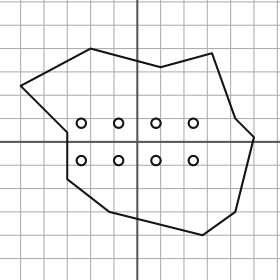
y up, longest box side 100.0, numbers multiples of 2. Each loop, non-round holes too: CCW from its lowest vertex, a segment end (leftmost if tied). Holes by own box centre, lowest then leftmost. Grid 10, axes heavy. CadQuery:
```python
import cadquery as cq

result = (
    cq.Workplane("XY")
    .moveTo(28.0, -40.0)
    .lineTo(42.0, -30.0)
    .lineTo(50.0, 2.0)
    .lineTo(42.0, 10.0)
    .lineTo(32.0, 38.0)
    .lineTo(10.0, 32.0)
    .lineTo(-20.0, 40.0)
    .lineTo(-50.0, 24.0)
    .lineTo(-30.0, 4.0)
    .lineTo(-30.0, -16.0)
    .lineTo(-12.0, -30.0)
    .close()
    .moveTo(-24.0, -8.0)
    .circle(2.0)
    .moveTo(-8.0, -8.0)
    .circle(2.0)
    .moveTo(8.0, -8.0)
    .circle(2.0)
    .moveTo(24.0, -8.0)
    .circle(2.0)
    .moveTo(-24.0, 8.0)
    .circle(2.0)
    .moveTo(-8.0, 8.0)
    .circle(2.0)
    .moveTo(8.0, 8.0)
    .circle(2.0)
    .moveTo(24.0, 8.0)
    .circle(2.0)
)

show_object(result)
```